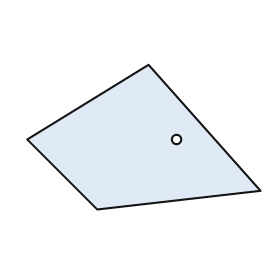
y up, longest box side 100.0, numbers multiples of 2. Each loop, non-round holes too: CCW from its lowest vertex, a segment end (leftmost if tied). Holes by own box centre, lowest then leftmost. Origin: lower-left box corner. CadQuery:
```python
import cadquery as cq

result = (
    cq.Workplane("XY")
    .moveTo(30.0, 0.0)
    .lineTo(100.0, 8.0)
    .lineTo(52.0, 62.0)
    .lineTo(0.0, 30.0)
    .close()
    .moveTo(64.0, 30.0)
    .circle(2.0)
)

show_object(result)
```